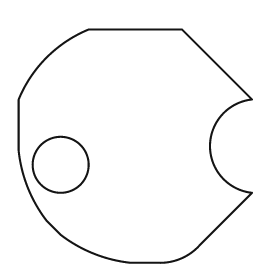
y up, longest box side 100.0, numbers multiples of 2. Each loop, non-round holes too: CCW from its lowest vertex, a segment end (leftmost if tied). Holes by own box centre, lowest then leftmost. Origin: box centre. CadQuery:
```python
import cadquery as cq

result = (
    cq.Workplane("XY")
    .moveTo(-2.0, -50.0)
    .lineTo(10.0, -50.0)
    .threePointArc((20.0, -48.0), (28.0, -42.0))
    .lineTo(50.0, -20.0)
    .threePointArc((32.0, 0.0), (50.0, 20.0))
    .lineTo(20.0, 50.0)
    .lineTo(-20.0, 50.0)
    .threePointArc((-38.0, 38.0), (-50.0, 20.0))
    .lineTo(-50.0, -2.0)
    .threePointArc((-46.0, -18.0), (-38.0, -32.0))
    .lineTo(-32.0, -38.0)
    .threePointArc((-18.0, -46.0), (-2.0, -50.0))
    .close()
    .moveTo(-32.0, -8.0)
    .circle(12.0)
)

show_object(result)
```